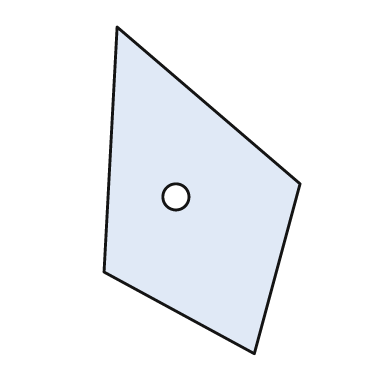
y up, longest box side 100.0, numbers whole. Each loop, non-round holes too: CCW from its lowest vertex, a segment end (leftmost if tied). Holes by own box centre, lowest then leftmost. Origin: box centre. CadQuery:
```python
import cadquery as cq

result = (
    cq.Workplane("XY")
    .moveTo(16.0, -50.0)
    .lineTo(30.0, 2.0)
    .lineTo(-26.0, 50.0)
    .lineTo(-30.0, -25.0)
    .close()
    .moveTo(-8.0, -2.0)
    .circle(4.0)
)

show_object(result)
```